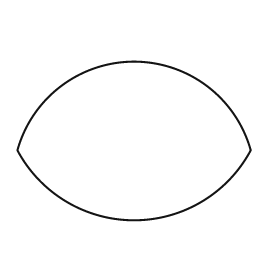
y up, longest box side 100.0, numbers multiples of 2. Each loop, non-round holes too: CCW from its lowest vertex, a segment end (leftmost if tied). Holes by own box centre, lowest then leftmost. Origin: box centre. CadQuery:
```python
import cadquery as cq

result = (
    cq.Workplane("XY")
    .moveTo(-50.0, -4.0)
    .threePointArc((0.0, -34.0), (50.0, -4.0))
    .threePointArc((0.0, 34.0), (-50.0, -4.0))
    .close()
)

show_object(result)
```